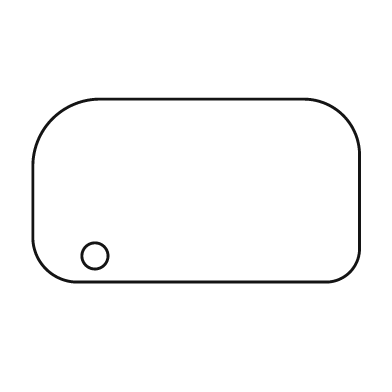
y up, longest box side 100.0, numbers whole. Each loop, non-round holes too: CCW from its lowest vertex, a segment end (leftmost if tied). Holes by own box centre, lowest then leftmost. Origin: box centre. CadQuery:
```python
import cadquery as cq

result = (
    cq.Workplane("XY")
    .moveTo(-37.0, -28.0)
    .lineTo(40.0, -28.0)
    .threePointArc((47.0, -25.0), (50.0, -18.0))
    .lineTo(50.0, 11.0)
    .threePointArc((45.0, 23.0), (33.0, 28.0))
    .lineTo(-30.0, 28.0)
    .threePointArc((-44.0, 22.0), (-50.0, 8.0))
    .lineTo(-50.0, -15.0)
    .threePointArc((-46.0, -24.0), (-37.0, -28.0))
    .close()
    .moveTo(-31.0, -20.0)
    .circle(4.0)
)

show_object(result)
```